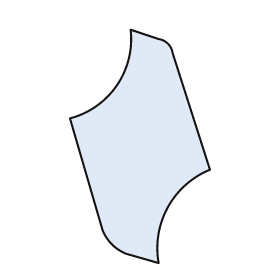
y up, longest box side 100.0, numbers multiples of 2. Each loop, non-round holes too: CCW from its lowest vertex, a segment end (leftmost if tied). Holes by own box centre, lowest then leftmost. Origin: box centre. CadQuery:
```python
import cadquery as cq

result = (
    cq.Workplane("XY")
    .moveTo(8.0, -50.0)
    .threePointArc((12.0, -26.0), (30.0, -10.0))
    .lineTo(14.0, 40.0)
    .threePointArc((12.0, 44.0), (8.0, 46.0))
    .lineTo(-4.0, 50.0)
    .threePointArc((-10.0, 26.0), (-30.0, 12.0))
    .lineTo(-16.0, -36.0)
    .threePointArc((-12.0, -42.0), (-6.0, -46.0))
    .close()
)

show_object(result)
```